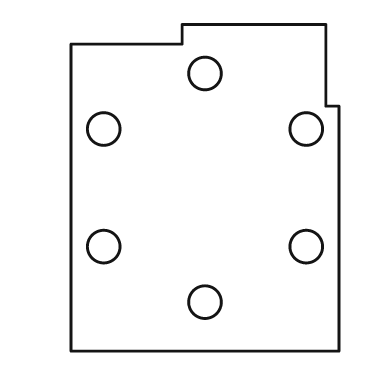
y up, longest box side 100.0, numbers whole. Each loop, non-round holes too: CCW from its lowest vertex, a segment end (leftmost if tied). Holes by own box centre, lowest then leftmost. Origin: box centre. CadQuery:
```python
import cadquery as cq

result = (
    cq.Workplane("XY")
    .moveTo(-41.0, -50.0)
    .lineTo(41.0, -50.0)
    .lineTo(41.0, 25.0)
    .lineTo(37.0, 25.0)
    .lineTo(37.0, 50.0)
    .lineTo(-7.0, 50.0)
    .lineTo(-7.0, 44.0)
    .lineTo(-41.0, 44.0)
    .close()
    .moveTo(0.0, -35.0)
    .circle(5.0)
    .moveTo(-31.0, -18.0)
    .circle(5.0)
    .moveTo(31.0, -18.0)
    .circle(5.0)
    .moveTo(-31.0, 18.0)
    .circle(5.0)
    .moveTo(31.0, 18.0)
    .circle(5.0)
    .moveTo(0.0, 35.0)
    .circle(5.0)
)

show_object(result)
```